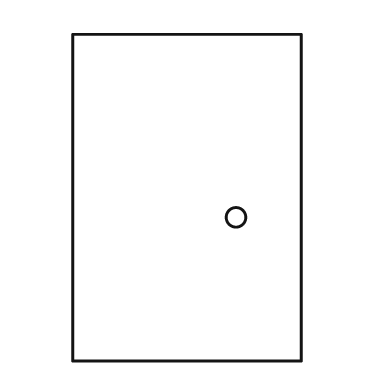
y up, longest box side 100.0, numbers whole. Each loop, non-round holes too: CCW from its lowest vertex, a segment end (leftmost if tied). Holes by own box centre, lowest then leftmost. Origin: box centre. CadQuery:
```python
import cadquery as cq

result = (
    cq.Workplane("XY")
    .moveTo(-35.0, -50.0)
    .lineTo(35.0, -50.0)
    .lineTo(35.0, 50.0)
    .lineTo(-35.0, 50.0)
    .close()
    .moveTo(15.0, -6.0)
    .circle(3.0)
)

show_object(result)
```